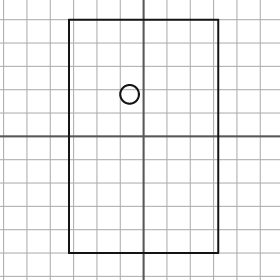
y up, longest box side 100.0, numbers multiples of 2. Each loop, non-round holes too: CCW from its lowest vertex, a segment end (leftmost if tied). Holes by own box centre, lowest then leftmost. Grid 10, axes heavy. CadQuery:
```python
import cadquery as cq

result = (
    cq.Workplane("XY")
    .moveTo(-32.0, -50.0)
    .lineTo(32.0, -50.0)
    .lineTo(32.0, 50.0)
    .lineTo(-32.0, 50.0)
    .close()
    .moveTo(-6.0, 18.0)
    .circle(4.0)
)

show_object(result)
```